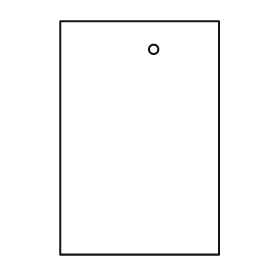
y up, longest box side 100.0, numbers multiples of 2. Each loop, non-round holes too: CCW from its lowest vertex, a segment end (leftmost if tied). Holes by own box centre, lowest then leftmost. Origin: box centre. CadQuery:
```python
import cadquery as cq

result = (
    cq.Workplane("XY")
    .moveTo(-34.0, -50.0)
    .lineTo(34.0, -50.0)
    .lineTo(34.0, 50.0)
    .lineTo(-34.0, 50.0)
    .close()
    .moveTo(6.0, 38.0)
    .circle(2.0)
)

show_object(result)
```